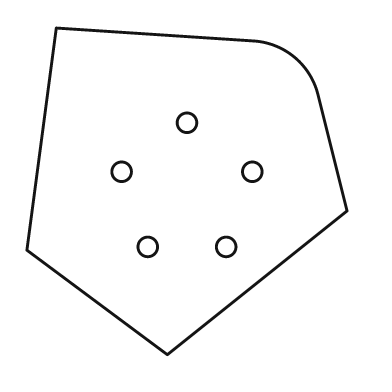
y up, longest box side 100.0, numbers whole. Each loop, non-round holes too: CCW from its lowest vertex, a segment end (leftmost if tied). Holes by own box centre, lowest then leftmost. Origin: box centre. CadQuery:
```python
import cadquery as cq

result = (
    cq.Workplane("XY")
    .moveTo(-6.0, -50.0)
    .lineTo(49.0, -6.0)
    .lineTo(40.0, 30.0)
    .threePointArc((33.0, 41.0), (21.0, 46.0))
    .lineTo(-40.0, 50.0)
    .lineTo(-49.0, -18.0)
    .close()
    .moveTo(-12.0, -17.0)
    .circle(3.0)
    .moveTo(12.0, -17.0)
    .circle(3.0)
    .moveTo(-20.0, 6.0)
    .circle(3.0)
    .moveTo(20.0, 6.0)
    .circle(3.0)
    .moveTo(0.0, 21.0)
    .circle(3.0)
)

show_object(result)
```